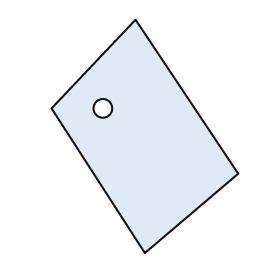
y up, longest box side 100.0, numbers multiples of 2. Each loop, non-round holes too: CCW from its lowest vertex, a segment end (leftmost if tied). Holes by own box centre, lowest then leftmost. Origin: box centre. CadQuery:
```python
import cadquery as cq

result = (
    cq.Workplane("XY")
    .moveTo(0.0, -50.0)
    .lineTo(40.0, -16.0)
    .lineTo(-4.0, 50.0)
    .lineTo(-40.0, 12.0)
    .close()
    .moveTo(-18.0, 12.0)
    .circle(4.0)
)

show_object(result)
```